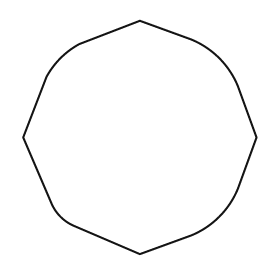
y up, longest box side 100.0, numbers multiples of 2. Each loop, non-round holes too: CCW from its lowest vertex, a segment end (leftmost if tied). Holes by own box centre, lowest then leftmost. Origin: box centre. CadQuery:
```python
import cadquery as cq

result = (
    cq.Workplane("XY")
    .moveTo(0.0, -50.0)
    .lineTo(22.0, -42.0)
    .threePointArc((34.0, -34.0), (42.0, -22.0))
    .lineTo(50.0, 0.0)
    .lineTo(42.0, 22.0)
    .threePointArc((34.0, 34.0), (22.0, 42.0))
    .lineTo(0.0, 50.0)
    .lineTo(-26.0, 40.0)
    .threePointArc((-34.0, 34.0), (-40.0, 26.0))
    .lineTo(-50.0, 0.0)
    .lineTo(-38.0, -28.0)
    .threePointArc((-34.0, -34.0), (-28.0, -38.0))
    .close()
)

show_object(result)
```